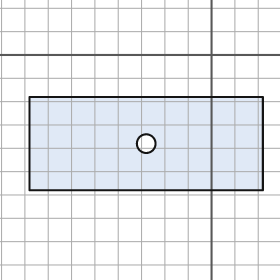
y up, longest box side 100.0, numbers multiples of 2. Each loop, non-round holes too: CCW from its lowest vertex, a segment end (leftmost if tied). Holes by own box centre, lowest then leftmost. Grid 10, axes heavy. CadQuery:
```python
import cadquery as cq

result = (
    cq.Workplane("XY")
    .moveTo(-78.0, -58.0)
    .lineTo(22.0, -58.0)
    .lineTo(22.0, -18.0)
    .lineTo(-78.0, -18.0)
    .close()
    .moveTo(-28.0, -38.0)
    .circle(4.0)
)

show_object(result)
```